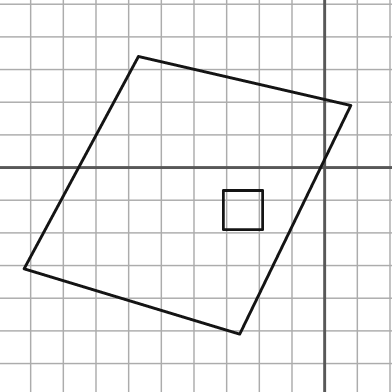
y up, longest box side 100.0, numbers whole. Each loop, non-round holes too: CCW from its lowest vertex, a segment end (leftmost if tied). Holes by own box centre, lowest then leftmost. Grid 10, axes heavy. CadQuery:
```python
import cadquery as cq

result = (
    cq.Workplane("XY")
    .moveTo(-26.0, -51.0)
    .lineTo(8.0, 19.0)
    .lineTo(-57.0, 34.0)
    .lineTo(-92.0, -31.0)
    .close()
    .moveTo(-31.0, -19.0)
    .lineTo(-19.0, -19.0)
    .lineTo(-19.0, -7.0)
    .lineTo(-31.0, -7.0)
    .close()
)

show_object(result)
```